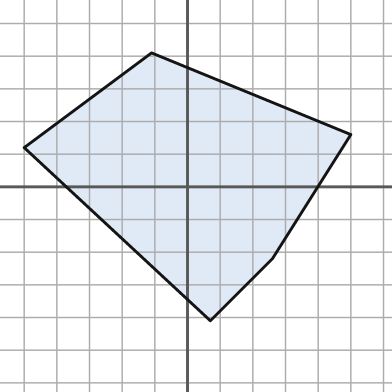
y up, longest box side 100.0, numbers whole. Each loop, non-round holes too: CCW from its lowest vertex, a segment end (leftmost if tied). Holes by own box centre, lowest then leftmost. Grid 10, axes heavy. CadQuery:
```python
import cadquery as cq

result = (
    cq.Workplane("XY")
    .moveTo(7.0, -41.0)
    .lineTo(26.0, -22.0)
    .lineTo(50.0, 16.0)
    .lineTo(-11.0, 41.0)
    .lineTo(-50.0, 12.0)
    .close()
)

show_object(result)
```